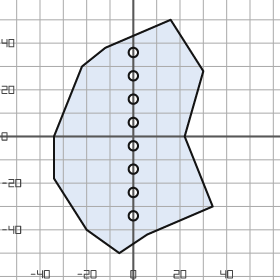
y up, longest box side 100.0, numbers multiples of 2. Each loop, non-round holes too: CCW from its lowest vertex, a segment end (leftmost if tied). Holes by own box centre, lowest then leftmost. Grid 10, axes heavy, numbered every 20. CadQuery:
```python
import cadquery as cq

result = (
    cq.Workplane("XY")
    .moveTo(-6.0, -50.0)
    .lineTo(6.0, -42.0)
    .lineTo(34.0, -30.0)
    .lineTo(22.0, 0.0)
    .lineTo(30.0, 28.0)
    .lineTo(16.0, 50.0)
    .lineTo(-12.0, 38.0)
    .lineTo(-22.0, 30.0)
    .lineTo(-34.0, 0.0)
    .lineTo(-34.0, -18.0)
    .lineTo(-20.0, -40.0)
    .close()
    .moveTo(0.0, -34.0)
    .circle(2.0)
    .moveTo(0.0, -24.0)
    .circle(2.0)
    .moveTo(0.0, -14.0)
    .circle(2.0)
    .moveTo(0.0, -4.0)
    .circle(2.0)
    .moveTo(0.0, 6.0)
    .circle(2.0)
    .moveTo(0.0, 16.0)
    .circle(2.0)
    .moveTo(0.0, 26.0)
    .circle(2.0)
    .moveTo(0.0, 36.0)
    .circle(2.0)
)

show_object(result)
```